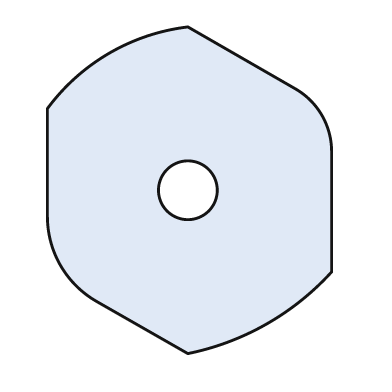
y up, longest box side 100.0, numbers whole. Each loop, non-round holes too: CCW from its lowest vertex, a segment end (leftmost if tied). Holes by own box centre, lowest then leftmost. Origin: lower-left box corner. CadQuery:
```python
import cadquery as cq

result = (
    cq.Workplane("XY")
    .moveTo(43.0, 0.0)
    .threePointArc((67.0, 9.0), (87.0, 25.0))
    .lineTo(87.0, 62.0)
    .threePointArc((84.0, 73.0), (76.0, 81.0))
    .lineTo(43.0, 100.0)
    .threePointArc((19.0, 92.0), (0.0, 75.0))
    .lineTo(0.0, 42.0)
    .threePointArc((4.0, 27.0), (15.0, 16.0))
    .close()
    .moveTo(43.0, 50.0)
    .circle(9.0)
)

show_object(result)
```